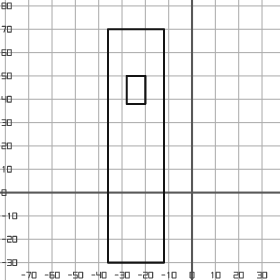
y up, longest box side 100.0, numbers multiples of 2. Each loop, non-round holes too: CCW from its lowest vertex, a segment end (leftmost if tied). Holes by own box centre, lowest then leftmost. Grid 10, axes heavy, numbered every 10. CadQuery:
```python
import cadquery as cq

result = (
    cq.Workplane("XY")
    .moveTo(-36.0, -30.0)
    .lineTo(-12.0, -30.0)
    .lineTo(-12.0, 70.0)
    .lineTo(-36.0, 70.0)
    .close()
    .moveTo(-28.0, 38.0)
    .lineTo(-20.0, 38.0)
    .lineTo(-20.0, 50.0)
    .lineTo(-28.0, 50.0)
    .close()
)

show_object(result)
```